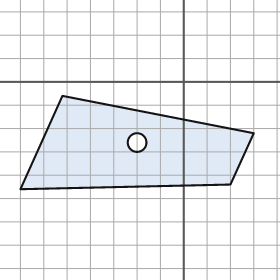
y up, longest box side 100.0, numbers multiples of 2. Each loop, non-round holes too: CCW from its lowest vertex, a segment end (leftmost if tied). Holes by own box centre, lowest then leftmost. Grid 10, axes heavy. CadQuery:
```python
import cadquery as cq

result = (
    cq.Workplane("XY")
    .moveTo(-70.0, -46.0)
    .lineTo(20.0, -44.0)
    .lineTo(30.0, -22.0)
    .lineTo(-52.0, -6.0)
    .close()
    .moveTo(-20.0, -26.0)
    .circle(4.0)
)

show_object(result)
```